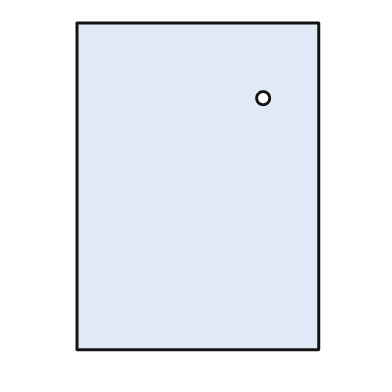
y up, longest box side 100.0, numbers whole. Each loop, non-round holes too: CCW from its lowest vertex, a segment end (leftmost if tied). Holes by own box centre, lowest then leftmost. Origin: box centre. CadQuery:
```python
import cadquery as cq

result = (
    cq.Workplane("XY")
    .moveTo(-37.0, -50.0)
    .lineTo(37.0, -50.0)
    .lineTo(37.0, 50.0)
    .lineTo(-37.0, 50.0)
    .close()
    .moveTo(20.0, 27.0)
    .circle(2.0)
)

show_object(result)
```